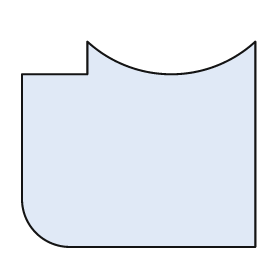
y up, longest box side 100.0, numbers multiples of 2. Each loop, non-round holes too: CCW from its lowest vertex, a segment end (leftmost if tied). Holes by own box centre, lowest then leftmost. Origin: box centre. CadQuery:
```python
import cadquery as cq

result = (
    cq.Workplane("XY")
    .moveTo(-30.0, -44.0)
    .lineTo(50.0, -44.0)
    .lineTo(50.0, 44.0)
    .threePointArc((14.0, 30.0), (-22.0, 44.0))
    .lineTo(-22.0, 30.0)
    .lineTo(-50.0, 30.0)
    .lineTo(-50.0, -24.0)
    .threePointArc((-44.0, -38.0), (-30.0, -44.0))
    .close()
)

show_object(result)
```